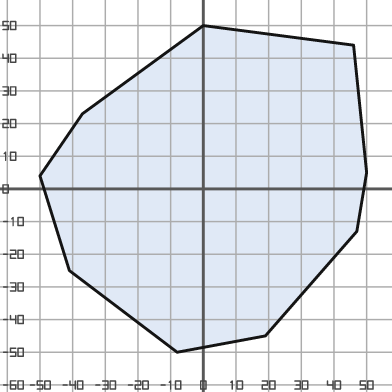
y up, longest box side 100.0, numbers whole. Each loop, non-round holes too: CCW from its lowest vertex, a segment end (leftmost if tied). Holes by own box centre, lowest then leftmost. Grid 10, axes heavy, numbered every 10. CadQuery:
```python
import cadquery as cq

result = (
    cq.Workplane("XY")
    .moveTo(-8.0, -50.0)
    .lineTo(19.0, -45.0)
    .lineTo(47.0, -13.0)
    .lineTo(50.0, 5.0)
    .lineTo(46.0, 44.0)
    .lineTo(0.0, 50.0)
    .lineTo(-37.0, 23.0)
    .lineTo(-50.0, 4.0)
    .lineTo(-41.0, -25.0)
    .close()
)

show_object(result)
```